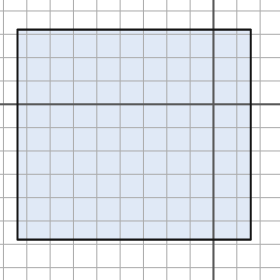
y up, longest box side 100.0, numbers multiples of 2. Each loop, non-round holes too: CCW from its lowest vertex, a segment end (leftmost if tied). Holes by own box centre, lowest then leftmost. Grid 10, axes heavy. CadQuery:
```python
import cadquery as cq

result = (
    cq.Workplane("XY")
    .moveTo(-84.0, -58.0)
    .lineTo(16.0, -58.0)
    .lineTo(16.0, 32.0)
    .lineTo(-84.0, 32.0)
    .close()
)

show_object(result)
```